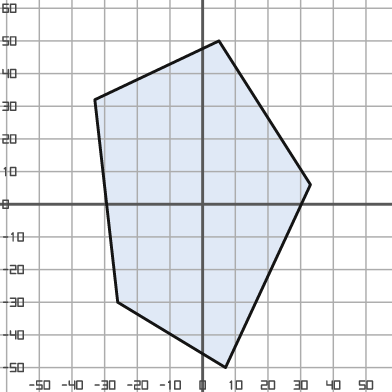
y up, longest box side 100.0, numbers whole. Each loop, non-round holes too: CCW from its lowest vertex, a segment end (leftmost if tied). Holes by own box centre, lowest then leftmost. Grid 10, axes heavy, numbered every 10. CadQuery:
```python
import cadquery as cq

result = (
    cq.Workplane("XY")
    .moveTo(7.0, -50.0)
    .lineTo(33.0, 6.0)
    .lineTo(5.0, 50.0)
    .lineTo(-33.0, 32.0)
    .lineTo(-26.0, -30.0)
    .close()
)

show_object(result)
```